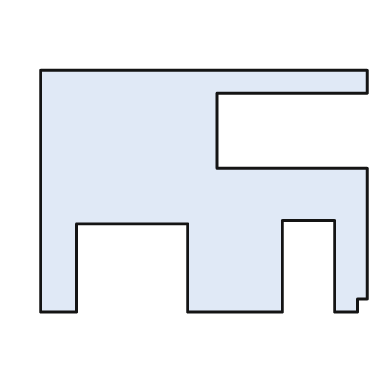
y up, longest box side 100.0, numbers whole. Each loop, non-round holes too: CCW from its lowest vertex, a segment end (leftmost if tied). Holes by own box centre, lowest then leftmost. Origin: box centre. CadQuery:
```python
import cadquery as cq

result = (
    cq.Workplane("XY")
    .moveTo(-50.0, -37.0)
    .lineTo(-39.0, -37.0)
    .lineTo(-39.0, -10.0)
    .lineTo(-5.0, -10.0)
    .lineTo(-5.0, -37.0)
    .lineTo(24.0, -37.0)
    .lineTo(24.0, -9.0)
    .lineTo(40.0, -9.0)
    .lineTo(40.0, -37.0)
    .lineTo(47.0, -37.0)
    .lineTo(47.0, -33.0)
    .lineTo(50.0, -33.0)
    .lineTo(50.0, 7.0)
    .lineTo(4.0, 7.0)
    .lineTo(4.0, 30.0)
    .lineTo(50.0, 30.0)
    .lineTo(50.0, 37.0)
    .lineTo(-50.0, 37.0)
    .close()
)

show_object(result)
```